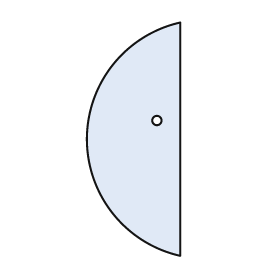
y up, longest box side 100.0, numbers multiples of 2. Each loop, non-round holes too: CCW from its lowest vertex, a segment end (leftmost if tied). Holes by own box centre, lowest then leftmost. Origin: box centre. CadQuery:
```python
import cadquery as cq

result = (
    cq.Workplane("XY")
    .moveTo(20.0, -50.0)
    .lineTo(20.0, 50.0)
    .threePointArc((-20.0, 0.0), (20.0, -50.0))
    .close()
    .moveTo(10.0, 8.0)
    .circle(2.0)
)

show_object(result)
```